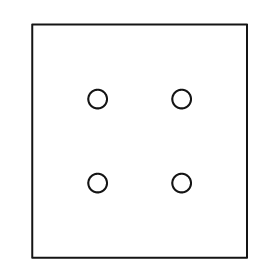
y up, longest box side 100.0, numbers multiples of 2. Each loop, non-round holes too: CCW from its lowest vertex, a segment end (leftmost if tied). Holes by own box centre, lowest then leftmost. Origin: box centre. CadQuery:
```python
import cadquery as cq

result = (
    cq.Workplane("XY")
    .moveTo(-46.0, -50.0)
    .lineTo(46.0, -50.0)
    .lineTo(46.0, 50.0)
    .lineTo(-46.0, 50.0)
    .close()
    .moveTo(-18.0, -18.0)
    .circle(4.0)
    .moveTo(18.0, -18.0)
    .circle(4.0)
    .moveTo(-18.0, 18.0)
    .circle(4.0)
    .moveTo(18.0, 18.0)
    .circle(4.0)
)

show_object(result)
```